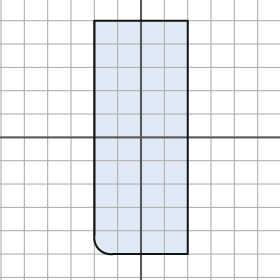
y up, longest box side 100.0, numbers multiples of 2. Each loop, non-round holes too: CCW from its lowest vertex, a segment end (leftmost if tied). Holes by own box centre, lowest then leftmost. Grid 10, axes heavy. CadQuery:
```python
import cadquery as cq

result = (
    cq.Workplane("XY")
    .moveTo(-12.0, -50.0)
    .lineTo(20.0, -50.0)
    .lineTo(20.0, 50.0)
    .lineTo(-20.0, 50.0)
    .lineTo(-20.0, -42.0)
    .threePointArc((-18.0, -48.0), (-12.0, -50.0))
    .close()
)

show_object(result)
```